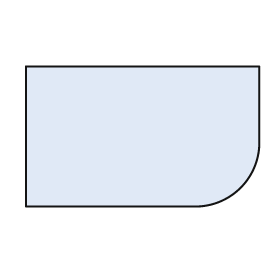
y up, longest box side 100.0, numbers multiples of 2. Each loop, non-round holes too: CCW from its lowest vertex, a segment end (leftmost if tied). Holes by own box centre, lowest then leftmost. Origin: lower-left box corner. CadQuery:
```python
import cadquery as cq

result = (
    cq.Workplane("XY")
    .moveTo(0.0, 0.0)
    .lineTo(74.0, 0.0)
    .threePointArc((92.0, 8.0), (100.0, 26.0))
    .lineTo(100.0, 60.0)
    .lineTo(0.0, 60.0)
    .close()
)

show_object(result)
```